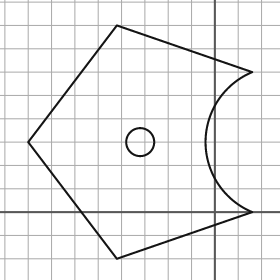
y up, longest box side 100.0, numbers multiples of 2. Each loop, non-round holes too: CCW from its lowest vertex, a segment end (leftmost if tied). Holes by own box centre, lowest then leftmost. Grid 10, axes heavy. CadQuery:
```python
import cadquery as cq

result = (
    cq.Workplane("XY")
    .moveTo(-42.0, -20.0)
    .lineTo(16.0, 0.0)
    .threePointArc((-4.0, 30.0), (16.0, 60.0))
    .lineTo(-42.0, 80.0)
    .lineTo(-80.0, 30.0)
    .close()
    .moveTo(-32.0, 30.0)
    .circle(6.0)
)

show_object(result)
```